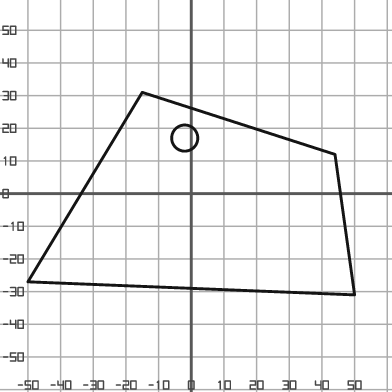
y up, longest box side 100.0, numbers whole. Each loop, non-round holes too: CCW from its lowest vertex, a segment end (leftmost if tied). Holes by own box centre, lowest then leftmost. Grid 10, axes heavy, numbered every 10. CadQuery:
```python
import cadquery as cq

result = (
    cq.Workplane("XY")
    .moveTo(50.0, -31.0)
    .lineTo(44.0, 12.0)
    .lineTo(-15.0, 31.0)
    .lineTo(-50.0, -27.0)
    .close()
    .moveTo(-2.0, 17.0)
    .circle(4.0)
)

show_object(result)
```